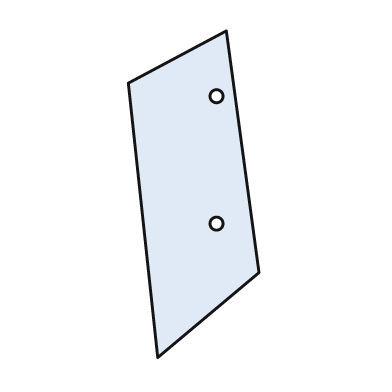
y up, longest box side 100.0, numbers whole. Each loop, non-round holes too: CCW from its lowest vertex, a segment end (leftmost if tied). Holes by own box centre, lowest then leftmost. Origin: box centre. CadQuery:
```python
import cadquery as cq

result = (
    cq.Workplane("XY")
    .moveTo(-11.0, -50.0)
    .lineTo(20.0, -24.0)
    .lineTo(10.0, 50.0)
    .lineTo(-20.0, 34.0)
    .close()
    .moveTo(7.0, -9.0)
    .circle(2.0)
    .moveTo(7.0, 30.0)
    .circle(2.0)
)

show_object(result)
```